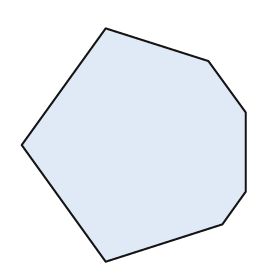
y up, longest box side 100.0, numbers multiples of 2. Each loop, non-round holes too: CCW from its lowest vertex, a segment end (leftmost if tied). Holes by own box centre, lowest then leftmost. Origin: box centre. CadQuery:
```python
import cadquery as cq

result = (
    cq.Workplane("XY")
    .moveTo(-12.0, -50.0)
    .lineTo(38.0, -34.0)
    .lineTo(48.0, -20.0)
    .lineTo(48.0, 14.0)
    .lineTo(32.0, 36.0)
    .lineTo(-12.0, 50.0)
    .lineTo(-48.0, 0.0)
    .close()
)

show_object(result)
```